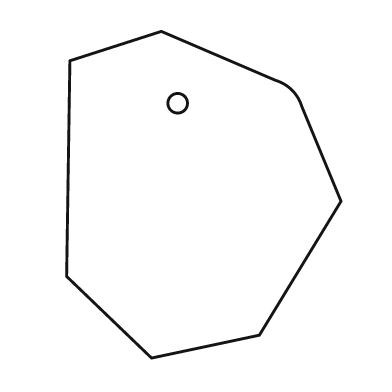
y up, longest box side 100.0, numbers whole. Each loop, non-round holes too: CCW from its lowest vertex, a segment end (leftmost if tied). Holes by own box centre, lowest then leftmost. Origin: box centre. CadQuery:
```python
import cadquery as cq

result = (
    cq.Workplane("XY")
    .moveTo(-16.0, -50.0)
    .lineTo(17.0, -43.0)
    .lineTo(42.0, -2.0)
    .lineTo(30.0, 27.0)
    .threePointArc((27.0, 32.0), (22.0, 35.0))
    .lineTo(-13.0, 50.0)
    .lineTo(-41.0, 41.0)
    .lineTo(-42.0, -25.0)
    .close()
    .moveTo(-8.0, 28.0)
    .circle(3.0)
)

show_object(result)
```